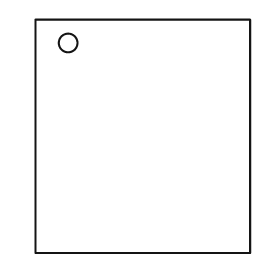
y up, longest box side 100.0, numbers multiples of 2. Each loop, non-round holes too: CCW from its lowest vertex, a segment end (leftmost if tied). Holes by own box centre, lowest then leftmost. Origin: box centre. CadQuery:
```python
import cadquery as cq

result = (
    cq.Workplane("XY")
    .moveTo(-46.0, -50.0)
    .lineTo(46.0, -50.0)
    .lineTo(46.0, 50.0)
    .lineTo(-46.0, 50.0)
    .close()
    .moveTo(-32.0, 40.0)
    .circle(4.0)
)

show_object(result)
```